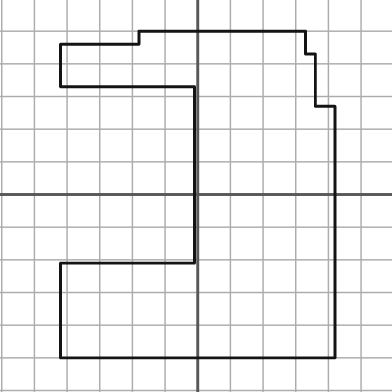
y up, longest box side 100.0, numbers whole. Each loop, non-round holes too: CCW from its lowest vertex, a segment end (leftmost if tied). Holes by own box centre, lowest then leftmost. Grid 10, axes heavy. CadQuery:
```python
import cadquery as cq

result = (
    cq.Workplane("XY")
    .moveTo(-42.0, -50.0)
    .lineTo(42.0, -50.0)
    .lineTo(42.0, 27.0)
    .lineTo(36.0, 27.0)
    .lineTo(36.0, 43.0)
    .lineTo(33.0, 43.0)
    .lineTo(33.0, 50.0)
    .lineTo(-18.0, 50.0)
    .lineTo(-18.0, 46.0)
    .lineTo(-42.0, 46.0)
    .lineTo(-42.0, 33.0)
    .lineTo(-1.0, 33.0)
    .lineTo(-1.0, -21.0)
    .lineTo(-42.0, -21.0)
    .close()
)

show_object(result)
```